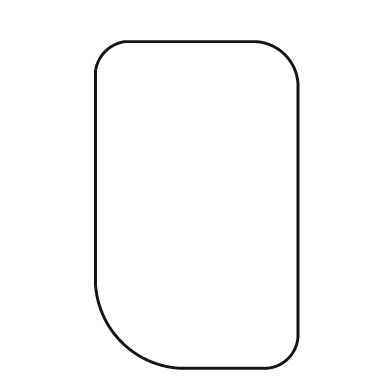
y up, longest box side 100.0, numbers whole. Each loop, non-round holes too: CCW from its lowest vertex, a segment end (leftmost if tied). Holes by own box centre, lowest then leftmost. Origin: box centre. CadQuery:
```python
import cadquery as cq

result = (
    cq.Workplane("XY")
    .moveTo(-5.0, -50.0)
    .lineTo(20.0, -50.0)
    .threePointArc((28.0, -47.0), (31.0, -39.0))
    .lineTo(31.0, 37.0)
    .threePointArc((27.0, 46.0), (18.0, 50.0))
    .lineTo(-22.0, 50.0)
    .threePointArc((-28.0, 47.0), (-31.0, 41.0))
    .lineTo(-31.0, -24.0)
    .threePointArc((-23.0, -42.0), (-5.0, -50.0))
    .close()
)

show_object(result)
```